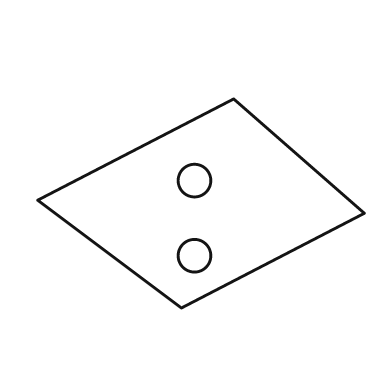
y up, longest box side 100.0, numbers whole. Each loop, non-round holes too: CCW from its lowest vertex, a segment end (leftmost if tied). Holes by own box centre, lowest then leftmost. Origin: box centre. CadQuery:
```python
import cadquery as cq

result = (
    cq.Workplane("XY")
    .moveTo(-6.0, -32.0)
    .lineTo(50.0, -3.0)
    .lineTo(10.0, 32.0)
    .lineTo(-50.0, 1.0)
    .close()
    .moveTo(-2.0, -16.0)
    .circle(5.0)
    .moveTo(-2.0, 7.0)
    .circle(5.0)
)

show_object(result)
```